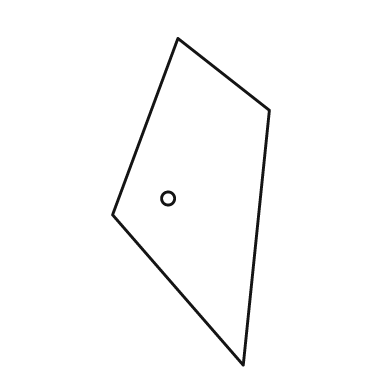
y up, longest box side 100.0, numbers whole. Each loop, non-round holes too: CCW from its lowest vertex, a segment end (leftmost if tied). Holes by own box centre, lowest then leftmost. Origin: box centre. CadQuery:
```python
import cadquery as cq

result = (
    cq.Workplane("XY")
    .moveTo(16.0, -50.0)
    .lineTo(24.0, 28.0)
    .lineTo(-4.0, 50.0)
    .lineTo(-24.0, -4.0)
    .close()
    .moveTo(-7.0, 1.0)
    .circle(2.0)
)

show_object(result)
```